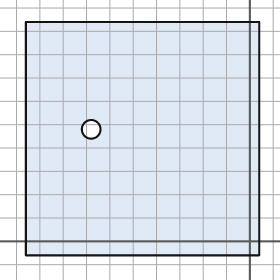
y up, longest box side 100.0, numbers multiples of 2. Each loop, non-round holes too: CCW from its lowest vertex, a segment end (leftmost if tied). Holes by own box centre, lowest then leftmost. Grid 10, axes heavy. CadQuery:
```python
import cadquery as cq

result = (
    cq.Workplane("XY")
    .moveTo(-96.0, -6.0)
    .lineTo(4.0, -6.0)
    .lineTo(4.0, 94.0)
    .lineTo(-96.0, 94.0)
    .close()
    .moveTo(-68.0, 48.0)
    .circle(4.0)
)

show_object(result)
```